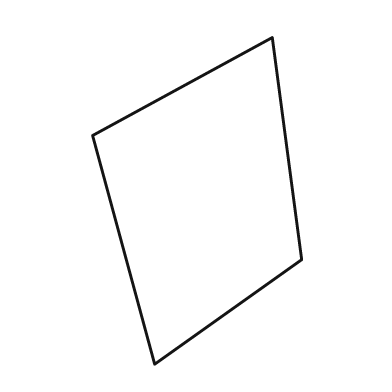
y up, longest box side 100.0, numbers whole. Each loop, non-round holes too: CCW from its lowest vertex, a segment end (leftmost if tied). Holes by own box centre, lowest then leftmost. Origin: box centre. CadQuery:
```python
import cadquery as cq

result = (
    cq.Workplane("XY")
    .moveTo(-13.0, -50.0)
    .lineTo(32.0, -18.0)
    .lineTo(23.0, 50.0)
    .lineTo(-32.0, 20.0)
    .close()
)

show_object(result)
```